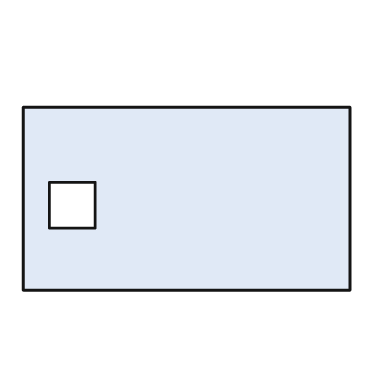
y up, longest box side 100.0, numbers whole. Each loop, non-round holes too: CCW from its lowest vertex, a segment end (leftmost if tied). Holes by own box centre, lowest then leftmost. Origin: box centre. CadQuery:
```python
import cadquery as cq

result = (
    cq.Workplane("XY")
    .moveTo(-50.0, -28.0)
    .lineTo(50.0, -28.0)
    .lineTo(50.0, 28.0)
    .lineTo(-50.0, 28.0)
    .close()
    .moveTo(-42.0, -9.0)
    .lineTo(-28.0, -9.0)
    .lineTo(-28.0, 5.0)
    .lineTo(-42.0, 5.0)
    .close()
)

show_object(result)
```